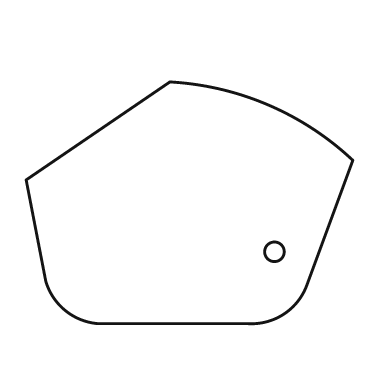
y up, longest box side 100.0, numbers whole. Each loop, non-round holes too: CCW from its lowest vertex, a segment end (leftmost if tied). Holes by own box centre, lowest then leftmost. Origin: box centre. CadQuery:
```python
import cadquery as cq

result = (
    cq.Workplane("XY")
    .moveTo(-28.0, -37.0)
    .lineTo(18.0, -37.0)
    .threePointArc((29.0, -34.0), (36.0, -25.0))
    .lineTo(50.0, 13.0)
    .threePointArc((24.0, 30.0), (-6.0, 37.0))
    .lineTo(-50.0, 7.0)
    .lineTo(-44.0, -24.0)
    .threePointArc((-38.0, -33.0), (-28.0, -37.0))
    .close()
    .moveTo(26.0, -15.0)
    .circle(3.0)
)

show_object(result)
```